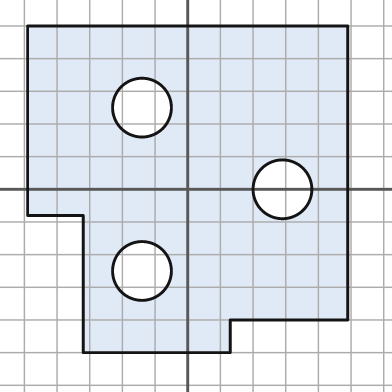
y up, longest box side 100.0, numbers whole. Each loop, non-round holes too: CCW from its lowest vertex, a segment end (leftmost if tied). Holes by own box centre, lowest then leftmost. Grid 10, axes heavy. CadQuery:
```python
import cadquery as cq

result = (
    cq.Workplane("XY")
    .moveTo(-32.0, -50.0)
    .lineTo(13.0, -50.0)
    .lineTo(13.0, -40.0)
    .lineTo(49.0, -40.0)
    .lineTo(49.0, 50.0)
    .lineTo(-49.0, 50.0)
    .lineTo(-49.0, -8.0)
    .lineTo(-32.0, -8.0)
    .close()
    .moveTo(-14.0, -25.0)
    .circle(9.0)
    .moveTo(29.0, 0.0)
    .circle(9.0)
    .moveTo(-14.0, 25.0)
    .circle(9.0)
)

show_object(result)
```